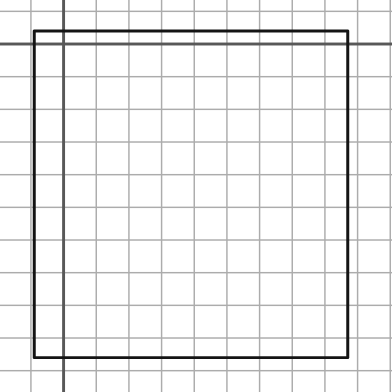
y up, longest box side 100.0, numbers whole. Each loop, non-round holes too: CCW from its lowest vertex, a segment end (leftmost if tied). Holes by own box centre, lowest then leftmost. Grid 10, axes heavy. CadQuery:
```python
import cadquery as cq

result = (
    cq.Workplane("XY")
    .moveTo(-9.0, -96.0)
    .lineTo(87.0, -96.0)
    .lineTo(87.0, 4.0)
    .lineTo(-9.0, 4.0)
    .close()
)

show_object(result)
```